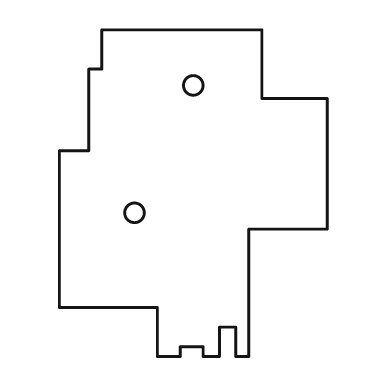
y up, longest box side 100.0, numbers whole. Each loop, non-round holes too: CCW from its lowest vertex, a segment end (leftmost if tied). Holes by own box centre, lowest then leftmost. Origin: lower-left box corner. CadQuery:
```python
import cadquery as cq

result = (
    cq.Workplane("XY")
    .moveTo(30.0, 0.0)
    .lineTo(37.0, 0.0)
    .lineTo(37.0, 3.0)
    .lineTo(44.0, 3.0)
    .lineTo(44.0, 0.0)
    .lineTo(49.0, 0.0)
    .lineTo(49.0, 9.0)
    .lineTo(54.0, 9.0)
    .lineTo(54.0, 0.0)
    .lineTo(58.0, 0.0)
    .lineTo(58.0, 39.0)
    .lineTo(82.0, 39.0)
    .lineTo(82.0, 79.0)
    .lineTo(62.0, 79.0)
    .lineTo(62.0, 100.0)
    .lineTo(13.0, 100.0)
    .lineTo(13.0, 88.0)
    .lineTo(9.0, 88.0)
    .lineTo(9.0, 63.0)
    .lineTo(0.0, 63.0)
    .lineTo(0.0, 15.0)
    .lineTo(30.0, 15.0)
    .close()
    .moveTo(23.0, 44.0)
    .circle(3.0)
    .moveTo(41.0, 83.0)
    .circle(3.0)
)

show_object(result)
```